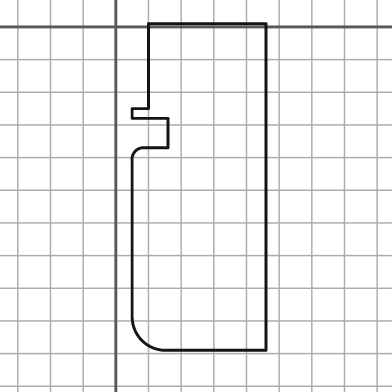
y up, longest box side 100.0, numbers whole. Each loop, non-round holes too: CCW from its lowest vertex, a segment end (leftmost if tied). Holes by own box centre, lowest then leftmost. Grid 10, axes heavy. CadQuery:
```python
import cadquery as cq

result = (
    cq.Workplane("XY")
    .moveTo(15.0, -99.0)
    .lineTo(46.0, -99.0)
    .lineTo(46.0, 1.0)
    .lineTo(10.0, 1.0)
    .lineTo(10.0, -25.0)
    .lineTo(5.0, -25.0)
    .lineTo(5.0, -28.0)
    .lineTo(16.0, -28.0)
    .lineTo(16.0, -37.0)
    .lineTo(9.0, -37.0)
    .threePointArc((6.0, -38.0), (5.0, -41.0))
    .lineTo(5.0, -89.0)
    .threePointArc((8.0, -96.0), (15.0, -99.0))
    .close()
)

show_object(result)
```